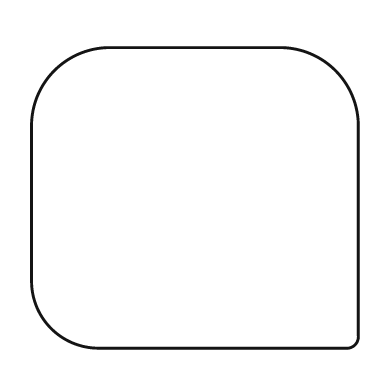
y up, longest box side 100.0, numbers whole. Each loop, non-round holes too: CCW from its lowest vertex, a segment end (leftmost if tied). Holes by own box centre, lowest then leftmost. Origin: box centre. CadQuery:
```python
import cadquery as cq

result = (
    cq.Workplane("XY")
    .moveTo(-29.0, -46.0)
    .lineTo(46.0, -46.0)
    .threePointArc((49.0, -45.0), (50.0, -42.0))
    .lineTo(50.0, 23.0)
    .threePointArc((43.0, 39.0), (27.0, 46.0))
    .lineTo(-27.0, 46.0)
    .threePointArc((-43.0, 39.0), (-50.0, 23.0))
    .lineTo(-50.0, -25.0)
    .threePointArc((-44.0, -40.0), (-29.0, -46.0))
    .close()
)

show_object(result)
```